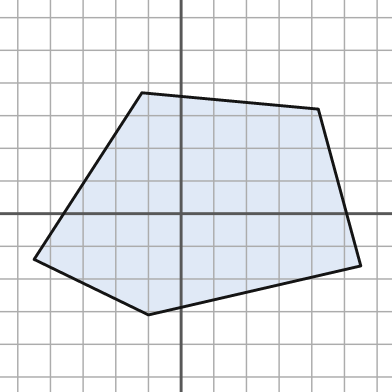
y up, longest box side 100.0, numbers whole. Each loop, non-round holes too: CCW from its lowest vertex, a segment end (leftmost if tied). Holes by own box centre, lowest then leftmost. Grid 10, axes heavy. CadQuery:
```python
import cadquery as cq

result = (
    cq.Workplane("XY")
    .moveTo(-10.0, -31.0)
    .lineTo(55.0, -16.0)
    .lineTo(42.0, 32.0)
    .lineTo(-12.0, 37.0)
    .lineTo(-45.0, -14.0)
    .close()
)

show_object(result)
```